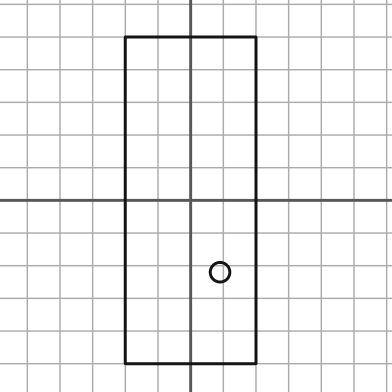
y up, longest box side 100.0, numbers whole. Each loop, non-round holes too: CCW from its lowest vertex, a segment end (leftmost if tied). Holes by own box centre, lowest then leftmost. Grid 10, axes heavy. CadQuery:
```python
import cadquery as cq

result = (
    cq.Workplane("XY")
    .moveTo(-20.0, -50.0)
    .lineTo(20.0, -50.0)
    .lineTo(20.0, 50.0)
    .lineTo(-20.0, 50.0)
    .close()
    .moveTo(9.0, -22.0)
    .circle(3.0)
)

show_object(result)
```